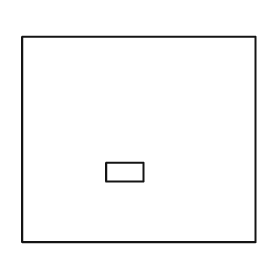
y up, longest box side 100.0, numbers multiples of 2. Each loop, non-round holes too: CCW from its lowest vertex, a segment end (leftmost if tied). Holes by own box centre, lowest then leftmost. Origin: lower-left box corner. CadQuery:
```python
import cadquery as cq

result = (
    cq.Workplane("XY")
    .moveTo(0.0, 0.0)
    .lineTo(100.0, 0.0)
    .lineTo(100.0, 88.0)
    .lineTo(0.0, 88.0)
    .close()
    .moveTo(36.0, 26.0)
    .lineTo(52.0, 26.0)
    .lineTo(52.0, 34.0)
    .lineTo(36.0, 34.0)
    .close()
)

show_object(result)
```